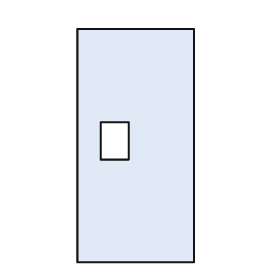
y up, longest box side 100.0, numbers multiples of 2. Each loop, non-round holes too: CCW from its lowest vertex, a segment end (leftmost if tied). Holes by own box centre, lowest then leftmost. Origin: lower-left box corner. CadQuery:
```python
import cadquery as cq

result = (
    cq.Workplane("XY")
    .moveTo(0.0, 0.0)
    .lineTo(50.0, 0.0)
    .lineTo(50.0, 100.0)
    .lineTo(0.0, 100.0)
    .close()
    .moveTo(10.0, 44.0)
    .lineTo(22.0, 44.0)
    .lineTo(22.0, 60.0)
    .lineTo(10.0, 60.0)
    .close()
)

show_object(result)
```